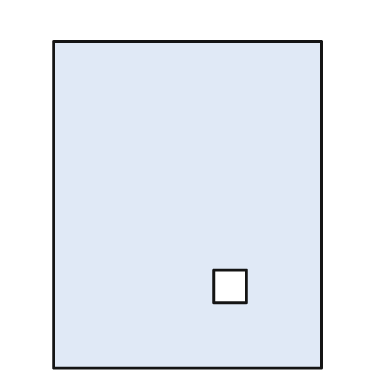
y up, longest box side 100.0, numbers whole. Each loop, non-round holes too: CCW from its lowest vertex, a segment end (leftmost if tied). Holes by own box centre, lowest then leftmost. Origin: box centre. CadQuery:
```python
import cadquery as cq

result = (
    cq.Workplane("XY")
    .moveTo(-41.0, -50.0)
    .lineTo(41.0, -50.0)
    .lineTo(41.0, 50.0)
    .lineTo(-41.0, 50.0)
    .close()
    .moveTo(8.0, -30.0)
    .lineTo(18.0, -30.0)
    .lineTo(18.0, -20.0)
    .lineTo(8.0, -20.0)
    .close()
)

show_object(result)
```